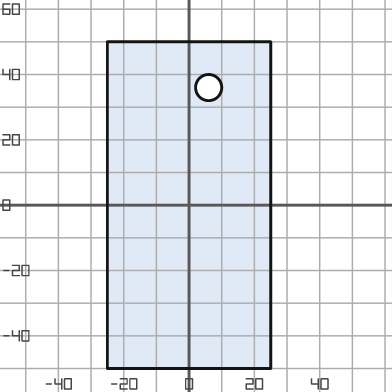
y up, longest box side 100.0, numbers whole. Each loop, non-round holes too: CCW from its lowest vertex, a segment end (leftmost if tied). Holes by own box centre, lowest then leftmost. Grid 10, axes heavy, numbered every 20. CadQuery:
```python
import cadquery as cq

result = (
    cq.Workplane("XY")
    .moveTo(-25.0, -50.0)
    .lineTo(25.0, -50.0)
    .lineTo(25.0, 50.0)
    .lineTo(-25.0, 50.0)
    .close()
    .moveTo(6.0, 36.0)
    .circle(4.0)
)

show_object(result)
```